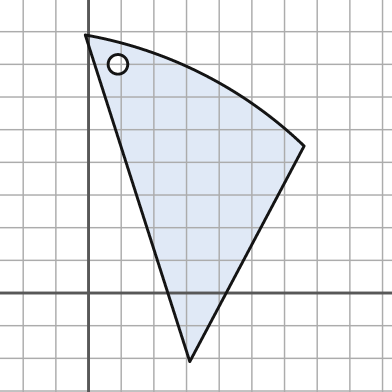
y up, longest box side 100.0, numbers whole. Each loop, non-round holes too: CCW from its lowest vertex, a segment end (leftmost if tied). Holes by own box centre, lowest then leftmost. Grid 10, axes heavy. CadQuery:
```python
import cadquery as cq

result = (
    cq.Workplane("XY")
    .moveTo(31.0, -21.0)
    .lineTo(66.0, 45.0)
    .threePointArc((35.0, 67.0), (-1.0, 79.0))
    .close()
    .moveTo(9.0, 70.0)
    .circle(3.0)
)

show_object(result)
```